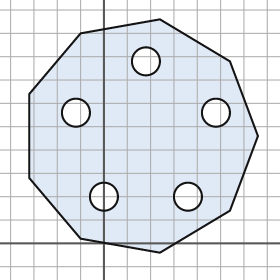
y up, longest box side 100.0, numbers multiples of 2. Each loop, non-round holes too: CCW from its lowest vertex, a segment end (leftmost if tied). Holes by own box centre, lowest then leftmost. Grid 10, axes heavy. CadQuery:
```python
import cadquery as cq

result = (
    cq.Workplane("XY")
    .moveTo(24.0, -4.0)
    .lineTo(54.0, 14.0)
    .lineTo(66.0, 46.0)
    .lineTo(54.0, 78.0)
    .lineTo(24.0, 96.0)
    .lineTo(-10.0, 90.0)
    .lineTo(-32.0, 64.0)
    .lineTo(-32.0, 28.0)
    .lineTo(-10.0, 2.0)
    .close()
    .moveTo(0.0, 20.0)
    .circle(6.0)
    .moveTo(36.0, 20.0)
    .circle(6.0)
    .moveTo(-12.0, 56.0)
    .circle(6.0)
    .moveTo(48.0, 56.0)
    .circle(6.0)
    .moveTo(18.0, 78.0)
    .circle(6.0)
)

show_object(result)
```